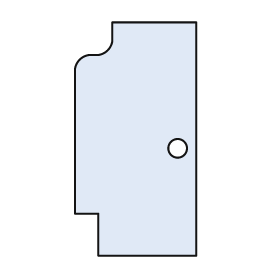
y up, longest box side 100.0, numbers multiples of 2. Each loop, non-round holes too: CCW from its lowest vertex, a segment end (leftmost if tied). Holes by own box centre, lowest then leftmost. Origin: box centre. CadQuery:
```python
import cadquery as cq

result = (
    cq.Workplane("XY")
    .moveTo(-16.0, -50.0)
    .lineTo(26.0, -50.0)
    .lineTo(26.0, 50.0)
    .lineTo(-10.0, 50.0)
    .lineTo(-10.0, 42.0)
    .threePointArc((-12.0, 38.0), (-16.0, 36.0))
    .lineTo(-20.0, 36.0)
    .threePointArc((-24.0, 34.0), (-26.0, 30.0))
    .lineTo(-26.0, -32.0)
    .lineTo(-16.0, -32.0)
    .close()
    .moveTo(18.0, -4.0)
    .circle(4.0)
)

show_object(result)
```